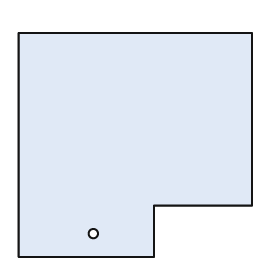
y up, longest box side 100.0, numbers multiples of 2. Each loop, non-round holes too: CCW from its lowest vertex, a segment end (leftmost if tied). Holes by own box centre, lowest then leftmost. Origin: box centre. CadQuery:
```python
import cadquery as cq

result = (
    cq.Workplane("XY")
    .moveTo(-50.0, -48.0)
    .lineTo(8.0, -48.0)
    .lineTo(8.0, -26.0)
    .lineTo(50.0, -26.0)
    .lineTo(50.0, 48.0)
    .lineTo(-50.0, 48.0)
    .close()
    .moveTo(-18.0, -38.0)
    .circle(2.0)
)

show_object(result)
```